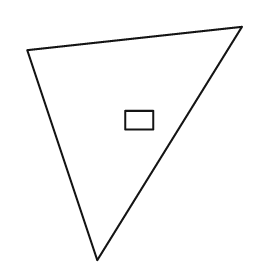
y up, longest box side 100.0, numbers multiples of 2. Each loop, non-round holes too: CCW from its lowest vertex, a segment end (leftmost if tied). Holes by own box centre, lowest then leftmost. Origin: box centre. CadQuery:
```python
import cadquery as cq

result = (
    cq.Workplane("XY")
    .moveTo(-16.0, -50.0)
    .lineTo(46.0, 50.0)
    .lineTo(-46.0, 40.0)
    .close()
    .moveTo(-4.0, 6.0)
    .lineTo(8.0, 6.0)
    .lineTo(8.0, 14.0)
    .lineTo(-4.0, 14.0)
    .close()
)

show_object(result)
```